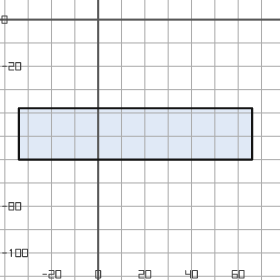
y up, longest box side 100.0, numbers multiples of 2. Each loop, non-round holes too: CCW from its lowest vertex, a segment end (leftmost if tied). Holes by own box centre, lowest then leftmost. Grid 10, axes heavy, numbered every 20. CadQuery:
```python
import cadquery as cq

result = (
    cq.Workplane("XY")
    .moveTo(-34.0, -60.0)
    .lineTo(66.0, -60.0)
    .lineTo(66.0, -38.0)
    .lineTo(-34.0, -38.0)
    .close()
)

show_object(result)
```